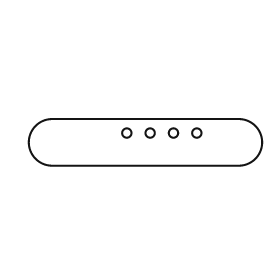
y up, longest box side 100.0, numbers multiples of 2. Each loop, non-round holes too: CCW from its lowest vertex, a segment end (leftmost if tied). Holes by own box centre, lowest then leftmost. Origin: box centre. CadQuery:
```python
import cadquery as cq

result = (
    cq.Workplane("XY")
    .moveTo(-40.0, -10.0)
    .lineTo(40.0, -10.0)
    .threePointArc((50.0, 0.0), (40.0, 10.0))
    .lineTo(-40.0, 10.0)
    .threePointArc((-50.0, 0.0), (-40.0, -10.0))
    .close()
    .moveTo(-8.0, 4.0)
    .circle(2.0)
    .moveTo(2.0, 4.0)
    .circle(2.0)
    .moveTo(12.0, 4.0)
    .circle(2.0)
    .moveTo(22.0, 4.0)
    .circle(2.0)
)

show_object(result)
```